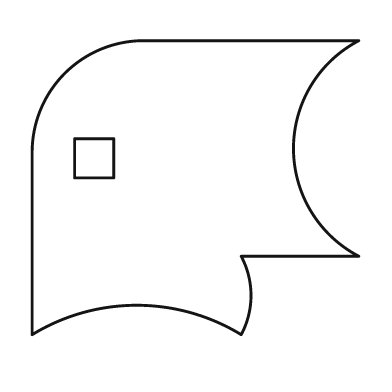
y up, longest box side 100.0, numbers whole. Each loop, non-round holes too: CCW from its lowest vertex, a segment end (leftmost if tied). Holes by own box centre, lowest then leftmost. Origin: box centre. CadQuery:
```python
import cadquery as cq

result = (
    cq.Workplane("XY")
    .moveTo(-50.0, -45.0)
    .threePointArc((-18.0, -36.0), (14.0, -45.0))
    .threePointArc((17.0, -33.0), (14.0, -21.0))
    .lineTo(50.0, -21.0)
    .threePointArc((30.0, 12.0), (50.0, 45.0))
    .lineTo(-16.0, 45.0)
    .threePointArc((-40.0, 35.0), (-50.0, 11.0))
    .close()
    .moveTo(-37.0, 3.0)
    .lineTo(-25.0, 3.0)
    .lineTo(-25.0, 15.0)
    .lineTo(-37.0, 15.0)
    .close()
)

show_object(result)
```